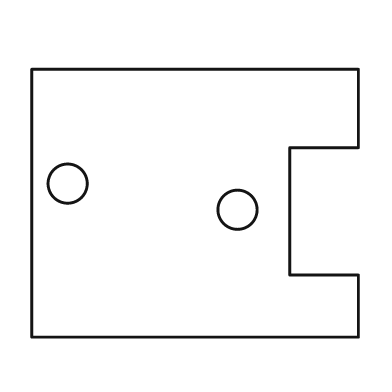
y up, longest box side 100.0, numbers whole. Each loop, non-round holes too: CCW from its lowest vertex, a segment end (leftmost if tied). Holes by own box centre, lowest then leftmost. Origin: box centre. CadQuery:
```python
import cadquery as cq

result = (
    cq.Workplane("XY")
    .moveTo(-50.0, -41.0)
    .lineTo(50.0, -41.0)
    .lineTo(50.0, -22.0)
    .lineTo(29.0, -22.0)
    .lineTo(29.0, 17.0)
    .lineTo(50.0, 17.0)
    .lineTo(50.0, 41.0)
    .lineTo(-50.0, 41.0)
    .close()
    .moveTo(13.0, -2.0)
    .circle(6.0)
    .moveTo(-39.0, 6.0)
    .circle(6.0)
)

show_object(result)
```